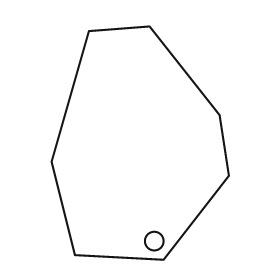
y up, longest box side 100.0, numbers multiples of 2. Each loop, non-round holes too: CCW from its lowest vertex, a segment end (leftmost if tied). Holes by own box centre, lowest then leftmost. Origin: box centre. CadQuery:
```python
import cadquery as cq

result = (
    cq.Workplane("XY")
    .moveTo(10.0, -50.0)
    .lineTo(38.0, -14.0)
    .lineTo(34.0, 12.0)
    .lineTo(4.0, 50.0)
    .lineTo(-22.0, 48.0)
    .lineTo(-38.0, -8.0)
    .lineTo(-28.0, -48.0)
    .close()
    .moveTo(6.0, -42.0)
    .circle(4.0)
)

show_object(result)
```